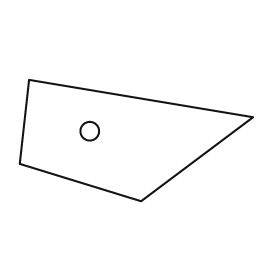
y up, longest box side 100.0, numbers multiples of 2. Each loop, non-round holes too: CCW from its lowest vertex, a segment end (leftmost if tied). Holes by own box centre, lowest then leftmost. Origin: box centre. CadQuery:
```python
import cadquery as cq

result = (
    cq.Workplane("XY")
    .moveTo(2.0, -26.0)
    .lineTo(50.0, 10.0)
    .lineTo(-46.0, 26.0)
    .lineTo(-50.0, -10.0)
    .close()
    .moveTo(-20.0, 4.0)
    .circle(4.0)
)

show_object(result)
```